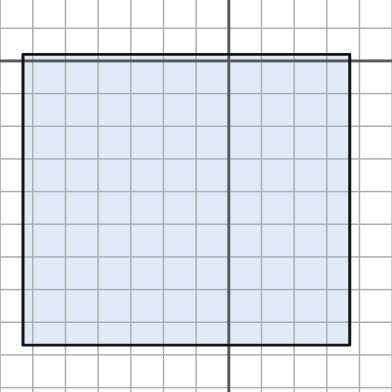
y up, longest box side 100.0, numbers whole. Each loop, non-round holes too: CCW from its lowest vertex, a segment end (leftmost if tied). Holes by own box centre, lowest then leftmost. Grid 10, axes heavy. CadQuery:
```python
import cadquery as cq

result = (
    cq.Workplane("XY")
    .moveTo(-63.0, -87.0)
    .lineTo(37.0, -87.0)
    .lineTo(37.0, 2.0)
    .lineTo(-63.0, 2.0)
    .close()
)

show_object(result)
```